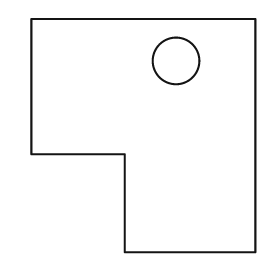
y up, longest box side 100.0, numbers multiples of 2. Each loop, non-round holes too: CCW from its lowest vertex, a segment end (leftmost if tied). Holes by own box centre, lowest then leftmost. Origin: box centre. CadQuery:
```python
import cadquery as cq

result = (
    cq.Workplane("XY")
    .moveTo(-8.0, -50.0)
    .lineTo(48.0, -50.0)
    .lineTo(48.0, 50.0)
    .lineTo(-48.0, 50.0)
    .lineTo(-48.0, -8.0)
    .lineTo(-8.0, -8.0)
    .close()
    .moveTo(14.0, 32.0)
    .circle(10.0)
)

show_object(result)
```